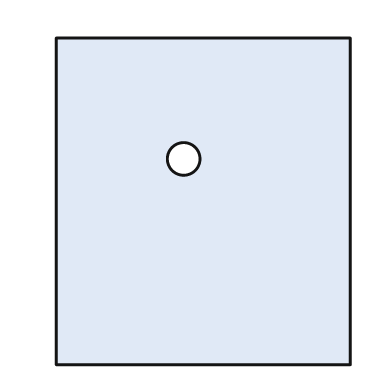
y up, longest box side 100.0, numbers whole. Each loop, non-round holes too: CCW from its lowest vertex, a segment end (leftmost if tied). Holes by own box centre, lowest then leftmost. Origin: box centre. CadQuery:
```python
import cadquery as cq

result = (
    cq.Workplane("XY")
    .moveTo(-45.0, -50.0)
    .lineTo(45.0, -50.0)
    .lineTo(45.0, 50.0)
    .lineTo(-45.0, 50.0)
    .close()
    .moveTo(-6.0, 13.0)
    .circle(5.0)
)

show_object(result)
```